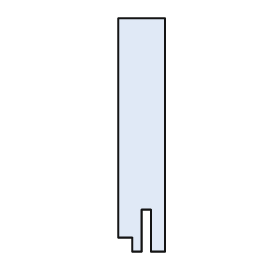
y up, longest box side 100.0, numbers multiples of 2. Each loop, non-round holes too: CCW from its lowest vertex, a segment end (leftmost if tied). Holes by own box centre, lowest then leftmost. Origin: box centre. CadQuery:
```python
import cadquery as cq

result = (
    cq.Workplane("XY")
    .moveTo(-4.0, -50.0)
    .lineTo(0.0, -50.0)
    .lineTo(0.0, -32.0)
    .lineTo(4.0, -32.0)
    .lineTo(4.0, -50.0)
    .lineTo(10.0, -50.0)
    .lineTo(10.0, 50.0)
    .lineTo(-10.0, 50.0)
    .lineTo(-10.0, -44.0)
    .lineTo(-4.0, -44.0)
    .close()
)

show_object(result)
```